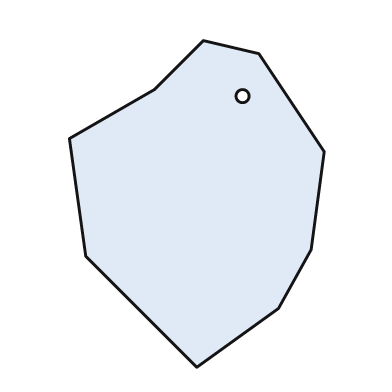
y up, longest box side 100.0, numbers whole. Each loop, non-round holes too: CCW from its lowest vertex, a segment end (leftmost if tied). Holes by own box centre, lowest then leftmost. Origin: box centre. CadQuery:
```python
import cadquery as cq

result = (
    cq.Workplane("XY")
    .moveTo(0.0, -50.0)
    .lineTo(25.0, -32.0)
    .lineTo(35.0, -14.0)
    .lineTo(39.0, 16.0)
    .lineTo(19.0, 46.0)
    .lineTo(2.0, 50.0)
    .lineTo(-13.0, 35.0)
    .lineTo(-39.0, 20.0)
    .lineTo(-34.0, -16.0)
    .close()
    .moveTo(14.0, 33.0)
    .circle(2.0)
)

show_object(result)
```